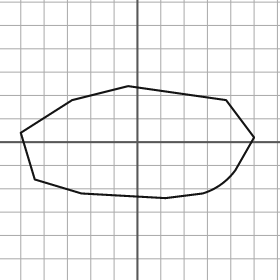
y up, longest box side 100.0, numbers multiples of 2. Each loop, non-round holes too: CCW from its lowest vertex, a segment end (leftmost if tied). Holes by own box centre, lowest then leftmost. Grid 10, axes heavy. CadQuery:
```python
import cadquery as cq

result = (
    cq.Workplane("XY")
    .moveTo(12.0, -24.0)
    .lineTo(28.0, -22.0)
    .threePointArc((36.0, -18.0), (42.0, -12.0))
    .lineTo(50.0, 2.0)
    .lineTo(38.0, 18.0)
    .lineTo(-4.0, 24.0)
    .lineTo(-28.0, 18.0)
    .lineTo(-50.0, 4.0)
    .lineTo(-44.0, -16.0)
    .lineTo(-24.0, -22.0)
    .close()
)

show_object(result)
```